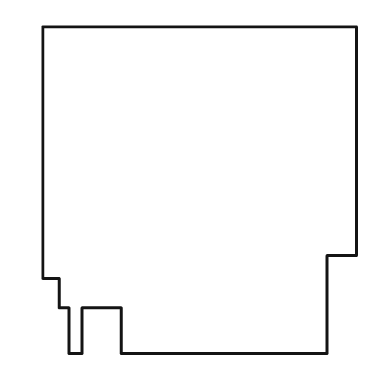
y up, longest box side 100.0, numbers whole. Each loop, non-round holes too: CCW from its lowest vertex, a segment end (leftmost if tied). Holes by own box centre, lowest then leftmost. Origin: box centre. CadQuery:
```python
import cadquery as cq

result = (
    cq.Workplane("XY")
    .moveTo(-40.0, -50.0)
    .lineTo(-36.0, -50.0)
    .lineTo(-36.0, -36.0)
    .lineTo(-24.0, -36.0)
    .lineTo(-24.0, -50.0)
    .lineTo(39.0, -50.0)
    .lineTo(39.0, -20.0)
    .lineTo(48.0, -20.0)
    .lineTo(48.0, 50.0)
    .lineTo(-48.0, 50.0)
    .lineTo(-48.0, -27.0)
    .lineTo(-43.0, -27.0)
    .lineTo(-43.0, -36.0)
    .lineTo(-40.0, -36.0)
    .close()
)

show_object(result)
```